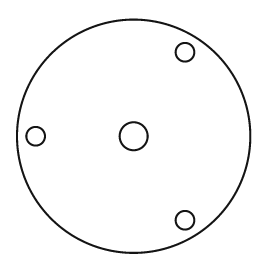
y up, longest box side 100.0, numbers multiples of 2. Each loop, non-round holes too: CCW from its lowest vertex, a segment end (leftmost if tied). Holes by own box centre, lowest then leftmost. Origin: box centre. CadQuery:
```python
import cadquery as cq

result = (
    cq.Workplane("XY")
    .moveTo(0.0, 0.0)
    .circle(50.0)
    .moveTo(22.0, -36.0)
    .circle(4.0)
    .moveTo(-42.0, 0.0)
    .circle(4.0)
    .moveTo(0.0, 0.0)
    .circle(6.0)
    .moveTo(22.0, 36.0)
    .circle(4.0)
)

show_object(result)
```